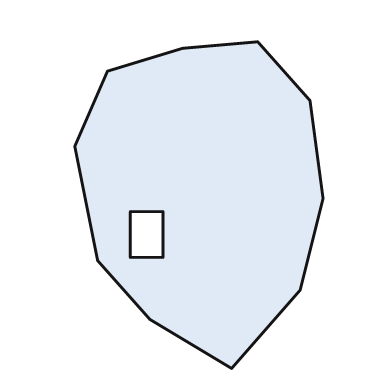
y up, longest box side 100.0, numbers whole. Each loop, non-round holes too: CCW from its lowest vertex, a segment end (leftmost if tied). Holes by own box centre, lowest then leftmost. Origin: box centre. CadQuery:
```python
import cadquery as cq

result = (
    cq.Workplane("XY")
    .moveTo(10.0, -50.0)
    .lineTo(31.0, -26.0)
    .lineTo(38.0, 2.0)
    .lineTo(34.0, 32.0)
    .lineTo(18.0, 50.0)
    .lineTo(-5.0, 48.0)
    .lineTo(-28.0, 41.0)
    .lineTo(-38.0, 18.0)
    .lineTo(-31.0, -17.0)
    .lineTo(-15.0, -35.0)
    .close()
    .moveTo(-21.0, -16.0)
    .lineTo(-11.0, -16.0)
    .lineTo(-11.0, -2.0)
    .lineTo(-21.0, -2.0)
    .close()
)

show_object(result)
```